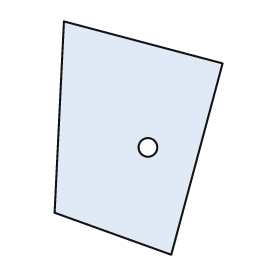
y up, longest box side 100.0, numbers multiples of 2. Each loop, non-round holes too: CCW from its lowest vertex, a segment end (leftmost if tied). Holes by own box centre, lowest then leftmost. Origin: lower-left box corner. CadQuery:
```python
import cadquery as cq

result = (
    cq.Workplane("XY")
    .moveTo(50.0, 0.0)
    .lineTo(72.0, 82.0)
    .lineTo(4.0, 100.0)
    .lineTo(0.0, 18.0)
    .close()
    .moveTo(40.0, 46.0)
    .circle(4.0)
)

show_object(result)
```